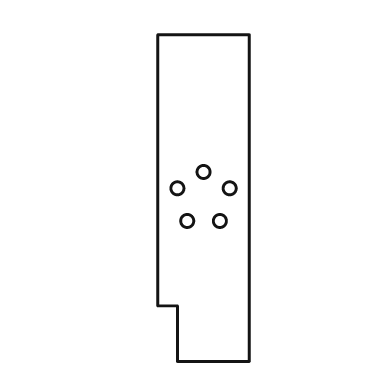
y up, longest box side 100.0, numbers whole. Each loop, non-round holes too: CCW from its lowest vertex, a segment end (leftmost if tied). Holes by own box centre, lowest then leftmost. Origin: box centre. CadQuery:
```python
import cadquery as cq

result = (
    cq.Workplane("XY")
    .moveTo(-8.0, -50.0)
    .lineTo(14.0, -50.0)
    .lineTo(14.0, 50.0)
    .lineTo(-14.0, 50.0)
    .lineTo(-14.0, -33.0)
    .lineTo(-8.0, -33.0)
    .close()
    .moveTo(-5.0, -7.0)
    .circle(2.0)
    .moveTo(5.0, -7.0)
    .circle(2.0)
    .moveTo(-8.0, 3.0)
    .circle(2.0)
    .moveTo(8.0, 3.0)
    .circle(2.0)
    .moveTo(0.0, 8.0)
    .circle(2.0)
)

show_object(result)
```